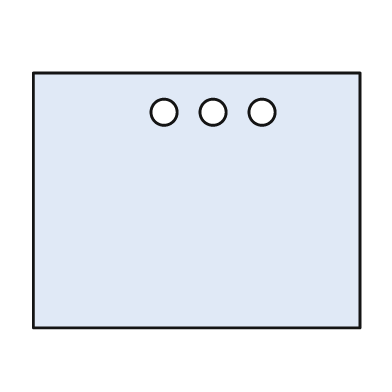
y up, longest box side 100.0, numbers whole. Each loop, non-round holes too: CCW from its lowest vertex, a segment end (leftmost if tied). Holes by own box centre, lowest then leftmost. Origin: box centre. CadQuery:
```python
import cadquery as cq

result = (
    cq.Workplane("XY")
    .moveTo(-50.0, -39.0)
    .lineTo(50.0, -39.0)
    .lineTo(50.0, 39.0)
    .lineTo(-50.0, 39.0)
    .close()
    .moveTo(-10.0, 27.0)
    .circle(4.0)
    .moveTo(5.0, 27.0)
    .circle(4.0)
    .moveTo(20.0, 27.0)
    .circle(4.0)
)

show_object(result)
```